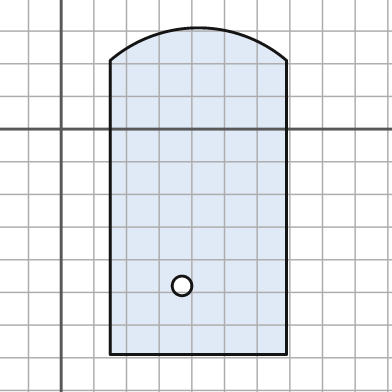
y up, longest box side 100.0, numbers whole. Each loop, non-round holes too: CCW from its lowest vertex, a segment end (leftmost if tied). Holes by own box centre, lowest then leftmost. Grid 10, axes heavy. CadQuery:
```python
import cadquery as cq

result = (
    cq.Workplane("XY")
    .moveTo(15.0, -69.0)
    .lineTo(69.0, -69.0)
    .lineTo(69.0, 21.0)
    .threePointArc((42.0, 31.0), (15.0, 21.0))
    .close()
    .moveTo(37.0, -48.0)
    .circle(3.0)
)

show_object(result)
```